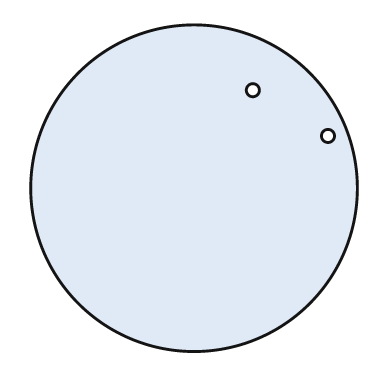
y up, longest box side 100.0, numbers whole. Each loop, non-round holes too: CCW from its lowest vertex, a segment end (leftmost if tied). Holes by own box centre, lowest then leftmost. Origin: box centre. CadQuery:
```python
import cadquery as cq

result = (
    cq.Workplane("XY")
    .moveTo(0.0, 0.0)
    .circle(50.0)
    .moveTo(41.0, 16.0)
    .circle(2.0)
    .moveTo(18.0, 30.0)
    .circle(2.0)
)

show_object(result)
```